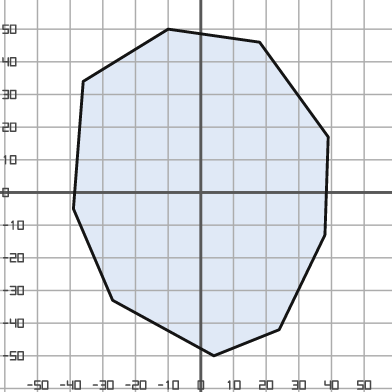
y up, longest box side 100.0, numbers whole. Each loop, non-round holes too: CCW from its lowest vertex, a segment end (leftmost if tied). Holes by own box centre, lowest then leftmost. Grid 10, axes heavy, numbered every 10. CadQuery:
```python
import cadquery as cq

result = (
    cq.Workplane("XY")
    .moveTo(4.0, -50.0)
    .lineTo(24.0, -42.0)
    .lineTo(38.0, -13.0)
    .lineTo(39.0, 17.0)
    .lineTo(18.0, 46.0)
    .lineTo(-10.0, 50.0)
    .lineTo(-36.0, 34.0)
    .lineTo(-39.0, -5.0)
    .lineTo(-27.0, -33.0)
    .close()
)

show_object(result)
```